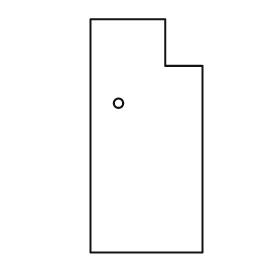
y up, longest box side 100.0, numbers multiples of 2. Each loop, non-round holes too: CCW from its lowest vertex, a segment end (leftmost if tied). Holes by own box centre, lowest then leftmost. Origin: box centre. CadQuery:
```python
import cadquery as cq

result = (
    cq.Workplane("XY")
    .moveTo(-24.0, -50.0)
    .lineTo(24.0, -50.0)
    .lineTo(24.0, 30.0)
    .lineTo(8.0, 30.0)
    .lineTo(8.0, 50.0)
    .lineTo(-24.0, 50.0)
    .close()
    .moveTo(-12.0, 14.0)
    .circle(2.0)
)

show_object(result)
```